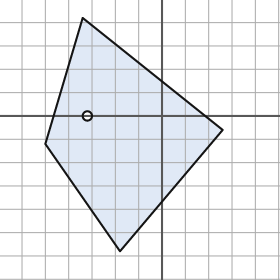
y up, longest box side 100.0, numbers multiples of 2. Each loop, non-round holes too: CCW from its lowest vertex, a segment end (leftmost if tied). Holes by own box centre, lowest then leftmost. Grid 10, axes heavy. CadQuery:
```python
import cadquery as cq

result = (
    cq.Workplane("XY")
    .moveTo(-18.0, -58.0)
    .lineTo(26.0, -6.0)
    .lineTo(-34.0, 42.0)
    .lineTo(-50.0, -12.0)
    .close()
    .moveTo(-32.0, 0.0)
    .circle(2.0)
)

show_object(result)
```